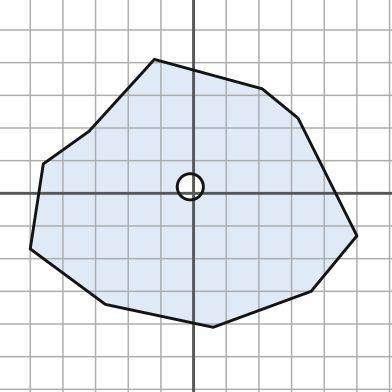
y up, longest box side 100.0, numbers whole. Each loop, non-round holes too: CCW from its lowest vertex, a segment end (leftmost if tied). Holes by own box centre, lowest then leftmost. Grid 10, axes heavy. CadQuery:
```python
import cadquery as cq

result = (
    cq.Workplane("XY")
    .moveTo(6.0, -41.0)
    .lineTo(36.0, -30.0)
    .lineTo(50.0, -13.0)
    .lineTo(32.0, 23.0)
    .lineTo(21.0, 32.0)
    .lineTo(-12.0, 41.0)
    .lineTo(-32.0, 19.0)
    .lineTo(-46.0, 9.0)
    .lineTo(-50.0, -17.0)
    .lineTo(-27.0, -34.0)
    .close()
    .moveTo(-1.0, 2.0)
    .circle(4.0)
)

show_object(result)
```